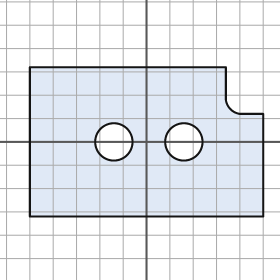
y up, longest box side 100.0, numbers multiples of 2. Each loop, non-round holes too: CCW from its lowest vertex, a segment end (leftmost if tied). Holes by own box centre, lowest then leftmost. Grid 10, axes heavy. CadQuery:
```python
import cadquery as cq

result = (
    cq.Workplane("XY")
    .moveTo(-50.0, -32.0)
    .lineTo(50.0, -32.0)
    .lineTo(50.0, 12.0)
    .lineTo(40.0, 12.0)
    .threePointArc((36.0, 14.0), (34.0, 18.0))
    .lineTo(34.0, 32.0)
    .lineTo(-50.0, 32.0)
    .close()
    .moveTo(-14.0, 0.0)
    .circle(8.0)
    .moveTo(16.0, 0.0)
    .circle(8.0)
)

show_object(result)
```